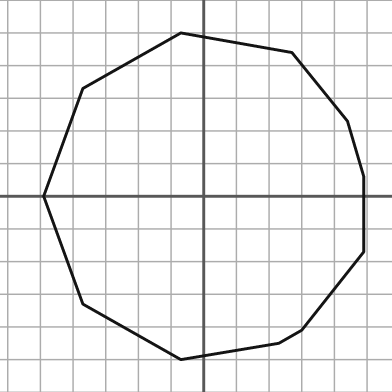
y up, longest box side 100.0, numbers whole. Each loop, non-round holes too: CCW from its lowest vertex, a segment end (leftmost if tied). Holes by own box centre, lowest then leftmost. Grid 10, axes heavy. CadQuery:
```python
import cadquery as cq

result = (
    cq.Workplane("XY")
    .moveTo(-7.0, -50.0)
    .lineTo(23.0, -45.0)
    .lineTo(30.0, -41.0)
    .lineTo(49.0, -17.0)
    .lineTo(49.0, 6.0)
    .lineTo(44.0, 23.0)
    .lineTo(27.0, 44.0)
    .lineTo(-7.0, 50.0)
    .lineTo(-37.0, 33.0)
    .lineTo(-49.0, 0.0)
    .lineTo(-37.0, -33.0)
    .close()
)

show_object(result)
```